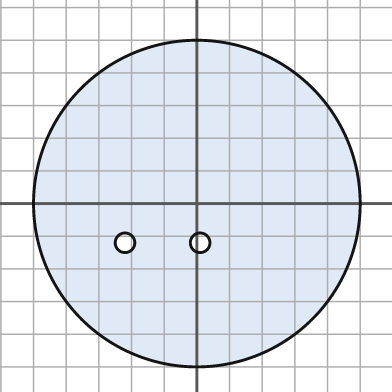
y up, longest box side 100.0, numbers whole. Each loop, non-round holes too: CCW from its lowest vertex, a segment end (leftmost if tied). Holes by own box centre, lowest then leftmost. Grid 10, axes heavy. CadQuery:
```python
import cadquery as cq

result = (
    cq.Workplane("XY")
    .moveTo(0.0, 0.0)
    .circle(50.0)
    .moveTo(-22.0, -12.0)
    .circle(3.0)
    .moveTo(1.0, -12.0)
    .circle(3.0)
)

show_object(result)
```